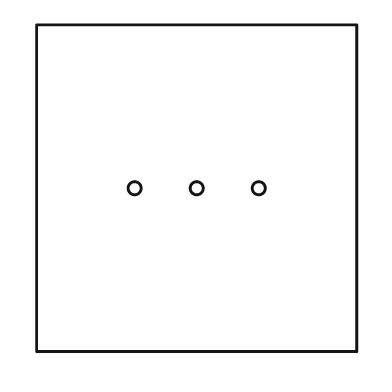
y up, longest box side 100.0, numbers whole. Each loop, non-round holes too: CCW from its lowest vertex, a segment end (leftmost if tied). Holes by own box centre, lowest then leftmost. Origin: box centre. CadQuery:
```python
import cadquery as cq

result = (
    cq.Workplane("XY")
    .moveTo(-49.0, -50.0)
    .lineTo(49.0, -50.0)
    .lineTo(49.0, 50.0)
    .lineTo(-49.0, 50.0)
    .close()
    .moveTo(-19.0, 0.0)
    .circle(2.0)
    .moveTo(0.0, 0.0)
    .circle(2.0)
    .moveTo(19.0, 0.0)
    .circle(2.0)
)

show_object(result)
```